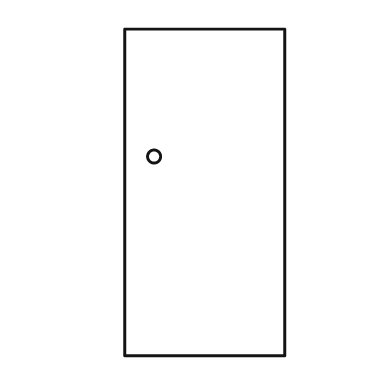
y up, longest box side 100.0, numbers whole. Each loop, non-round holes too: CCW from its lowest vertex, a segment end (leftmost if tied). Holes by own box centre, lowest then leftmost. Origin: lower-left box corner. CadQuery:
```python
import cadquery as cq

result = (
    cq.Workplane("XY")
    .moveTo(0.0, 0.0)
    .lineTo(49.0, 0.0)
    .lineTo(49.0, 100.0)
    .lineTo(0.0, 100.0)
    .close()
    .moveTo(9.0, 61.0)
    .circle(2.0)
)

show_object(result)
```